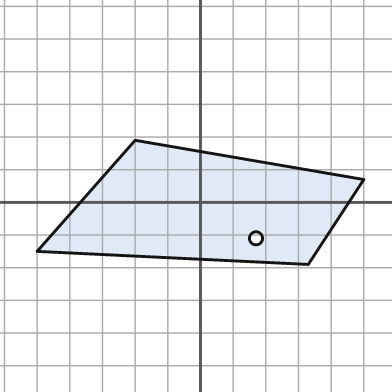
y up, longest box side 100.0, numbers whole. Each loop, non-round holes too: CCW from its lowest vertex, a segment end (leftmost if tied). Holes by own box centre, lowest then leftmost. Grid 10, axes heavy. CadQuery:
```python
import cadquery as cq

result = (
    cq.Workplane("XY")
    .moveTo(33.0, -19.0)
    .lineTo(50.0, 7.0)
    .lineTo(-20.0, 19.0)
    .lineTo(-50.0, -15.0)
    .close()
    .moveTo(17.0, -11.0)
    .circle(2.0)
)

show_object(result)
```